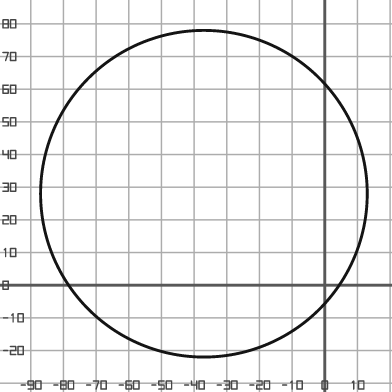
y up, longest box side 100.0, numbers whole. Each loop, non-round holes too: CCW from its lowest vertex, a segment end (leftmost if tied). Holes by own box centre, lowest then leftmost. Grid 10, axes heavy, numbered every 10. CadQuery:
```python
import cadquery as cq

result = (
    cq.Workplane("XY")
    .moveTo(-37.0, 28.0)
    .circle(50.0)
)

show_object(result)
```